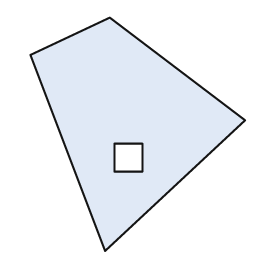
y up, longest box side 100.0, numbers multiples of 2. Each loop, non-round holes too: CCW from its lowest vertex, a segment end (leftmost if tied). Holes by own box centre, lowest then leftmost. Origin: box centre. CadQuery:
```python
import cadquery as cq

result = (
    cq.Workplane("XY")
    .moveTo(-14.0, -50.0)
    .lineTo(46.0, 6.0)
    .lineTo(-12.0, 50.0)
    .lineTo(-46.0, 34.0)
    .close()
    .moveTo(-10.0, -16.0)
    .lineTo(2.0, -16.0)
    .lineTo(2.0, -4.0)
    .lineTo(-10.0, -4.0)
    .close()
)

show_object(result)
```